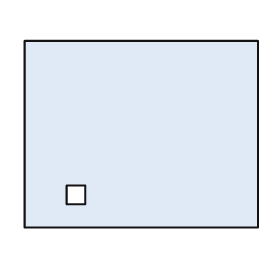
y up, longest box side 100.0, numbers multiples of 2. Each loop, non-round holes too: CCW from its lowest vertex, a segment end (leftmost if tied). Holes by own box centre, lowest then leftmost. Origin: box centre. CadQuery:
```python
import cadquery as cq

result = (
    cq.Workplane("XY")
    .moveTo(-50.0, -40.0)
    .lineTo(50.0, -40.0)
    .lineTo(50.0, 40.0)
    .lineTo(-50.0, 40.0)
    .close()
    .moveTo(-32.0, -30.0)
    .lineTo(-24.0, -30.0)
    .lineTo(-24.0, -22.0)
    .lineTo(-32.0, -22.0)
    .close()
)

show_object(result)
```